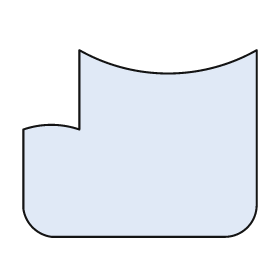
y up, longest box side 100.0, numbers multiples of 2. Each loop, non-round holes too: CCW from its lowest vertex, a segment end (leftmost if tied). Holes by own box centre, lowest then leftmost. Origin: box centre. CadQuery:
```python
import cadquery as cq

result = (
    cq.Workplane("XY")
    .moveTo(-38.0, -40.0)
    .lineTo(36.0, -40.0)
    .threePointArc((46.0, -36.0), (50.0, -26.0))
    .lineTo(50.0, 40.0)
    .threePointArc((12.0, 30.0), (-26.0, 40.0))
    .lineTo(-26.0, 6.0)
    .threePointArc((-38.0, 8.0), (-50.0, 6.0))
    .lineTo(-50.0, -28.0)
    .threePointArc((-46.0, -36.0), (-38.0, -40.0))
    .close()
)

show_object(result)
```